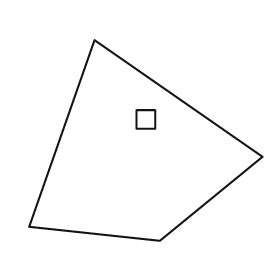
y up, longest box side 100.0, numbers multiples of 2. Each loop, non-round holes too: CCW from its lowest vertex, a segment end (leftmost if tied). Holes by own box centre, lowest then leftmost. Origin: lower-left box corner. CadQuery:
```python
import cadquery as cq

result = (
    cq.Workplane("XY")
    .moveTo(56.0, 0.0)
    .lineTo(100.0, 36.0)
    .lineTo(28.0, 86.0)
    .lineTo(0.0, 6.0)
    .close()
    .moveTo(46.0, 48.0)
    .lineTo(54.0, 48.0)
    .lineTo(54.0, 56.0)
    .lineTo(46.0, 56.0)
    .close()
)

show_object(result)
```